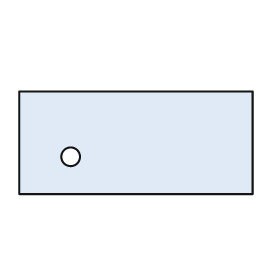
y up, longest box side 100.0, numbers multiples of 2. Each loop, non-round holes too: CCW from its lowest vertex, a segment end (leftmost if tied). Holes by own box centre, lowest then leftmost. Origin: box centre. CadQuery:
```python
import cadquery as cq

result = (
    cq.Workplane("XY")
    .moveTo(-50.0, -22.0)
    .lineTo(50.0, -22.0)
    .lineTo(50.0, 22.0)
    .lineTo(-50.0, 22.0)
    .close()
    .moveTo(-28.0, -6.0)
    .circle(4.0)
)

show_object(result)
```